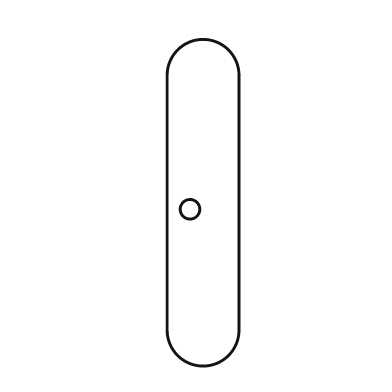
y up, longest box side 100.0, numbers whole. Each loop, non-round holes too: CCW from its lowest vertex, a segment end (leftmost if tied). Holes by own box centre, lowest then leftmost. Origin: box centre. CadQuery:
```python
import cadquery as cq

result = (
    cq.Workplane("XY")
    .moveTo(-11.0, -39.0)
    .threePointArc((0.0, -50.0), (11.0, -39.0))
    .lineTo(11.0, 39.0)
    .threePointArc((0.0, 50.0), (-11.0, 39.0))
    .close()
    .moveTo(-4.0, -2.0)
    .circle(3.0)
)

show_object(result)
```